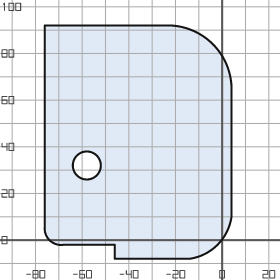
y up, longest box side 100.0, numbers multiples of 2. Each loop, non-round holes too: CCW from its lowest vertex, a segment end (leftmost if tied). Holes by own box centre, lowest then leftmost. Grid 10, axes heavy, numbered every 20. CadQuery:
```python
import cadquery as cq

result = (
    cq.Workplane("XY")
    .moveTo(-46.0, -8.0)
    .lineTo(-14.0, -8.0)
    .threePointArc((-2.0, -2.0), (4.0, 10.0))
    .lineTo(4.0, 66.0)
    .threePointArc((-4.0, 84.0), (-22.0, 92.0))
    .lineTo(-76.0, 92.0)
    .lineTo(-76.0, 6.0)
    .threePointArc((-74.0, 0.0), (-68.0, -2.0))
    .lineTo(-46.0, -2.0)
    .close()
    .moveTo(-58.0, 32.0)
    .circle(6.0)
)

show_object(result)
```